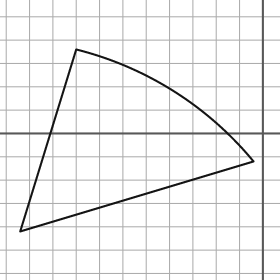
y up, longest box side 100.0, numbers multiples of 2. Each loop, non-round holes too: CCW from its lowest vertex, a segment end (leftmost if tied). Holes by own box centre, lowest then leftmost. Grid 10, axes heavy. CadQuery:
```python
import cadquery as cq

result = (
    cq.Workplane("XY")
    .moveTo(-104.0, -42.0)
    .lineTo(-4.0, -12.0)
    .threePointArc((-38.0, 18.0), (-80.0, 36.0))
    .close()
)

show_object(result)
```